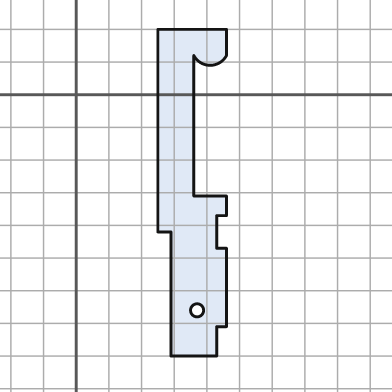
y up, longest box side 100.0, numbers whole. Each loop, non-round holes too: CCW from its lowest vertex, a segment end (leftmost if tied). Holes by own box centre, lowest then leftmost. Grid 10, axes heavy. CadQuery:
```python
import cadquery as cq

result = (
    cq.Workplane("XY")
    .moveTo(29.0, -80.0)
    .lineTo(43.0, -80.0)
    .lineTo(43.0, -71.0)
    .lineTo(46.0, -71.0)
    .lineTo(46.0, -47.0)
    .lineTo(43.0, -47.0)
    .lineTo(43.0, -37.0)
    .lineTo(46.0, -37.0)
    .lineTo(46.0, -31.0)
    .lineTo(36.0, -31.0)
    .lineTo(36.0, 12.0)
    .threePointArc((41.0, 9.0), (46.0, 12.0))
    .lineTo(46.0, 20.0)
    .lineTo(25.0, 20.0)
    .lineTo(25.0, -42.0)
    .lineTo(29.0, -42.0)
    .close()
    .moveTo(37.0, -66.0)
    .circle(2.0)
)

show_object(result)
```